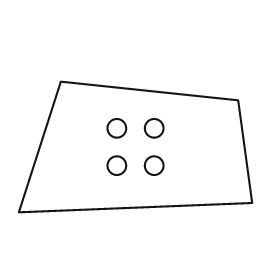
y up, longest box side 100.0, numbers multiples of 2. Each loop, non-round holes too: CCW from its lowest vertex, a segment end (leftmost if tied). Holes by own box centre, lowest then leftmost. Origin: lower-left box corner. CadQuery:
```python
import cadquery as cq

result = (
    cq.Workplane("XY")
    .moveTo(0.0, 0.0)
    .lineTo(100.0, 4.0)
    .lineTo(94.0, 48.0)
    .lineTo(18.0, 56.0)
    .close()
    .moveTo(42.0, 20.0)
    .circle(4.0)
    .moveTo(58.0, 20.0)
    .circle(4.0)
    .moveTo(42.0, 36.0)
    .circle(4.0)
    .moveTo(58.0, 36.0)
    .circle(4.0)
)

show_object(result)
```